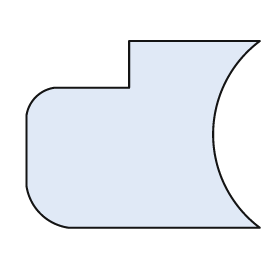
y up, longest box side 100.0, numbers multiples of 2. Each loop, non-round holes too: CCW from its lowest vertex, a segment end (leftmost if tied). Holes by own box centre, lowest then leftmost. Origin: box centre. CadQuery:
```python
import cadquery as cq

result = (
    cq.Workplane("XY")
    .moveTo(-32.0, -40.0)
    .lineTo(50.0, -40.0)
    .threePointArc((30.0, 0.0), (50.0, 40.0))
    .lineTo(-6.0, 40.0)
    .lineTo(-6.0, 20.0)
    .lineTo(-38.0, 20.0)
    .threePointArc((-46.0, 16.0), (-50.0, 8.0))
    .lineTo(-50.0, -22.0)
    .threePointArc((-44.0, -34.0), (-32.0, -40.0))
    .close()
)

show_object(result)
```